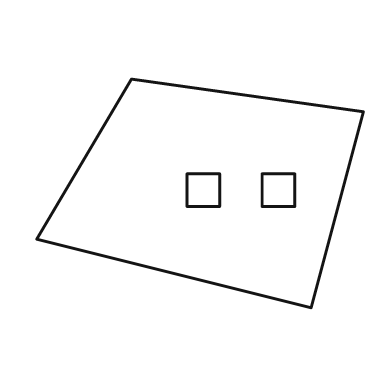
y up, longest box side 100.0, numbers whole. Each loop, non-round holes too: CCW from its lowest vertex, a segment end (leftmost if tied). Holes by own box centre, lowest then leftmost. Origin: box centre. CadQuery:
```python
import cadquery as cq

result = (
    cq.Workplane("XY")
    .moveTo(34.0, -35.0)
    .lineTo(50.0, 25.0)
    .lineTo(-21.0, 35.0)
    .lineTo(-50.0, -14.0)
    .close()
    .moveTo(-4.0, -4.0)
    .lineTo(6.0, -4.0)
    .lineTo(6.0, 6.0)
    .lineTo(-4.0, 6.0)
    .close()
    .moveTo(19.0, -4.0)
    .lineTo(29.0, -4.0)
    .lineTo(29.0, 6.0)
    .lineTo(19.0, 6.0)
    .close()
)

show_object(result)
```